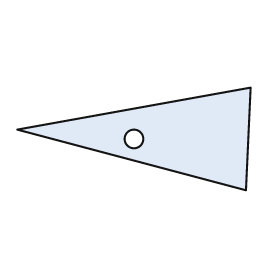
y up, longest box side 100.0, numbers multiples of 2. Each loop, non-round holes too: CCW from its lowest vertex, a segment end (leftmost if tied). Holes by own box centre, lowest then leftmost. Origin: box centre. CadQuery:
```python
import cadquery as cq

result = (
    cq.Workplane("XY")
    .moveTo(48.0, -22.0)
    .lineTo(50.0, 22.0)
    .lineTo(-50.0, 4.0)
    .close()
    .moveTo(0.0, 0.0)
    .circle(4.0)
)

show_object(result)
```